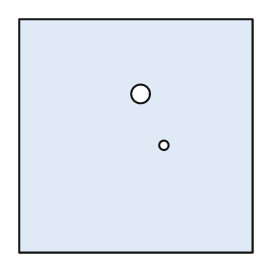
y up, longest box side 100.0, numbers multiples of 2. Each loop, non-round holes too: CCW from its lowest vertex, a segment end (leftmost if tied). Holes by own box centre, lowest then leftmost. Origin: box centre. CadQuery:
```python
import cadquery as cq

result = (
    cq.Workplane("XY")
    .moveTo(-50.0, -50.0)
    .lineTo(50.0, -50.0)
    .lineTo(50.0, 50.0)
    .lineTo(-50.0, 50.0)
    .close()
    .moveTo(12.0, -4.0)
    .circle(2.0)
    .moveTo(2.0, 18.0)
    .circle(4.0)
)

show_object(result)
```